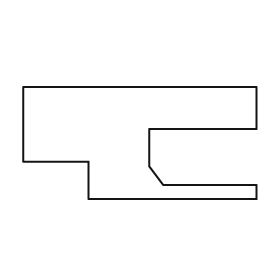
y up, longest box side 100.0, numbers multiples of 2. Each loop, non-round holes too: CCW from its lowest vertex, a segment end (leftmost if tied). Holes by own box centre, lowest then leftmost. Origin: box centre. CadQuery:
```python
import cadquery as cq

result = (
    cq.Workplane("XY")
    .moveTo(-22.0, -24.0)
    .lineTo(50.0, -24.0)
    .lineTo(50.0, -18.0)
    .lineTo(10.0, -18.0)
    .lineTo(4.0, -10.0)
    .lineTo(4.0, 6.0)
    .lineTo(50.0, 6.0)
    .lineTo(50.0, 24.0)
    .lineTo(-50.0, 24.0)
    .lineTo(-50.0, -8.0)
    .lineTo(-22.0, -8.0)
    .close()
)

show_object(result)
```